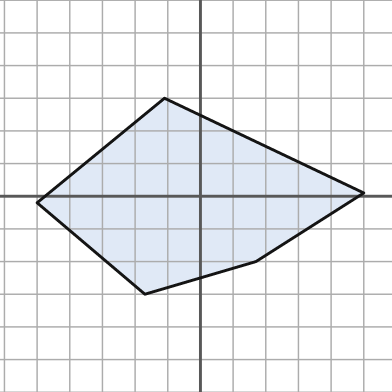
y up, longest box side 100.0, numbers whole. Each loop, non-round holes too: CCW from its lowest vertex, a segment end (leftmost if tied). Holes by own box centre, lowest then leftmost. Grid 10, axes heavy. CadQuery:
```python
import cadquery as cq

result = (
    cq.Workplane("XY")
    .moveTo(-17.0, -30.0)
    .lineTo(17.0, -20.0)
    .lineTo(50.0, 1.0)
    .lineTo(-11.0, 30.0)
    .lineTo(-50.0, -2.0)
    .close()
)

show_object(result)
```